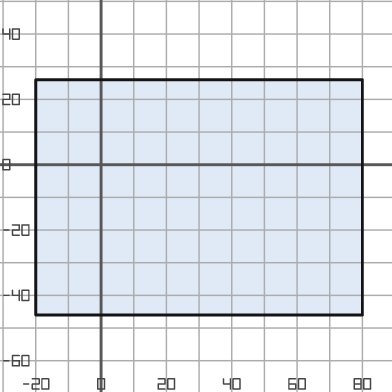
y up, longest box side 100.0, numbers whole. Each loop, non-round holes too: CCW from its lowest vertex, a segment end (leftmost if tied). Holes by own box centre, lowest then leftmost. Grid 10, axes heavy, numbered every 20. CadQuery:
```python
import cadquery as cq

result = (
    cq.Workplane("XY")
    .moveTo(-20.0, -46.0)
    .lineTo(80.0, -46.0)
    .lineTo(80.0, 26.0)
    .lineTo(-20.0, 26.0)
    .close()
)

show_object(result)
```